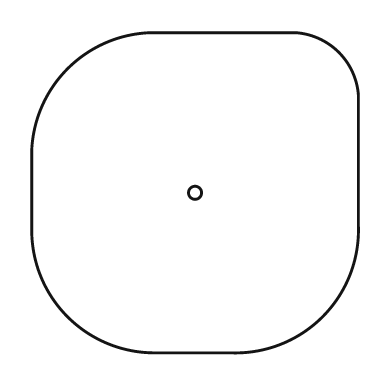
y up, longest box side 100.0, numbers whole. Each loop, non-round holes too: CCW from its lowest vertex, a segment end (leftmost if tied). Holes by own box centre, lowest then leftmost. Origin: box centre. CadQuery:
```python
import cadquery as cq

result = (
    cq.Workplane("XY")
    .moveTo(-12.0, -49.0)
    .lineTo(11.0, -49.0)
    .threePointArc((39.0, -38.0), (50.0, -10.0))
    .lineTo(50.0, 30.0)
    .threePointArc((44.0, 43.0), (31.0, 49.0))
    .lineTo(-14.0, 49.0)
    .threePointArc((-39.0, 38.0), (-50.0, 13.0))
    .lineTo(-50.0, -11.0)
    .threePointArc((-39.0, -38.0), (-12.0, -49.0))
    .close()
    .moveTo(0.0, 0.0)
    .circle(2.0)
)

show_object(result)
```